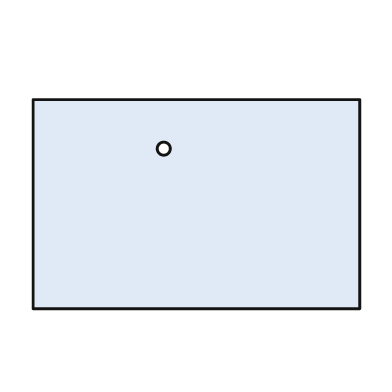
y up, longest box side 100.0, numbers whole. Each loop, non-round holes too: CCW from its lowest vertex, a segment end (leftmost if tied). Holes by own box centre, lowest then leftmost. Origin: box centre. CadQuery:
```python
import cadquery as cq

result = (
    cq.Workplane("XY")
    .moveTo(-50.0, -32.0)
    .lineTo(50.0, -32.0)
    .lineTo(50.0, 32.0)
    .lineTo(-50.0, 32.0)
    .close()
    .moveTo(-10.0, 17.0)
    .circle(2.0)
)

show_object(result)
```